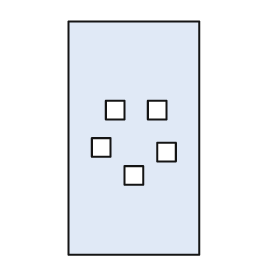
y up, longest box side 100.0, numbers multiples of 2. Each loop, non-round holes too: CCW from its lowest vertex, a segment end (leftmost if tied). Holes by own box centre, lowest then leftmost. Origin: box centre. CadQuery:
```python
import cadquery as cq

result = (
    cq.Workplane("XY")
    .moveTo(-28.0, -50.0)
    .lineTo(28.0, -50.0)
    .lineTo(28.0, 50.0)
    .lineTo(-28.0, 50.0)
    .close()
    .moveTo(-4.0, -20.0)
    .lineTo(4.0, -20.0)
    .lineTo(4.0, -12.0)
    .lineTo(-4.0, -12.0)
    .close()
    .moveTo(10.0, -10.0)
    .lineTo(18.0, -10.0)
    .lineTo(18.0, -2.0)
    .lineTo(10.0, -2.0)
    .close()
    .moveTo(-18.0, -8.0)
    .lineTo(-10.0, -8.0)
    .lineTo(-10.0, 0.0)
    .lineTo(-18.0, 0.0)
    .close()
    .moveTo(-12.0, 8.0)
    .lineTo(-4.0, 8.0)
    .lineTo(-4.0, 16.0)
    .lineTo(-12.0, 16.0)
    .close()
    .moveTo(6.0, 8.0)
    .lineTo(14.0, 8.0)
    .lineTo(14.0, 16.0)
    .lineTo(6.0, 16.0)
    .close()
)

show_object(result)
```